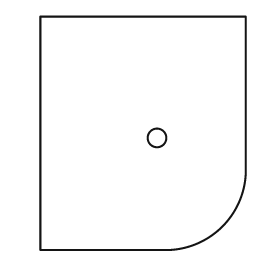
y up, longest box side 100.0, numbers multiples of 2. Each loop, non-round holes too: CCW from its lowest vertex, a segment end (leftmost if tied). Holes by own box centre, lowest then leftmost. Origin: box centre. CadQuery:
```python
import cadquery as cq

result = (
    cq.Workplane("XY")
    .moveTo(-44.0, -50.0)
    .lineTo(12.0, -50.0)
    .threePointArc((34.0, -40.0), (44.0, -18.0))
    .lineTo(44.0, 50.0)
    .lineTo(-44.0, 50.0)
    .close()
    .moveTo(6.0, -2.0)
    .circle(4.0)
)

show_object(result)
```